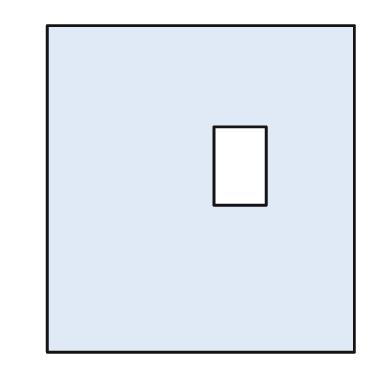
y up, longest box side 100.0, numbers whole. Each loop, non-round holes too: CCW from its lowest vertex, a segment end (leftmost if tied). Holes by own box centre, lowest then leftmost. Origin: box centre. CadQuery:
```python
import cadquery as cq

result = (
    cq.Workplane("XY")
    .moveTo(-47.0, -50.0)
    .lineTo(47.0, -50.0)
    .lineTo(47.0, 50.0)
    .lineTo(-47.0, 50.0)
    .close()
    .moveTo(4.0, -5.0)
    .lineTo(20.0, -5.0)
    .lineTo(20.0, 19.0)
    .lineTo(4.0, 19.0)
    .close()
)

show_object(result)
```